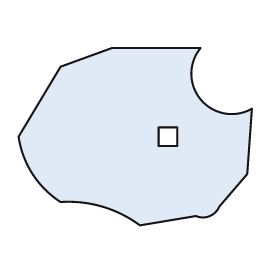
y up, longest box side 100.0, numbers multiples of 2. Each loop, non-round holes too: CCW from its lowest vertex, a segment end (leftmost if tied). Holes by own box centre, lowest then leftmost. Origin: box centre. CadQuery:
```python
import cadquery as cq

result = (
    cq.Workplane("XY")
    .moveTo(2.0, -38.0)
    .lineTo(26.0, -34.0)
    .threePointArc((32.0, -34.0), (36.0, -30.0))
    .lineTo(48.0, -16.0)
    .lineTo(50.0, 12.0)
    .threePointArc((28.0, 16.0), (28.0, 38.0))
    .lineTo(-10.0, 38.0)
    .lineTo(-32.0, 30.0)
    .lineTo(-50.0, 0.0)
    .threePointArc((-44.0, -16.0), (-32.0, -28.0))
    .threePointArc((-14.0, -30.0), (2.0, -38.0))
    .close()
    .moveTo(10.0, -4.0)
    .lineTo(18.0, -4.0)
    .lineTo(18.0, 4.0)
    .lineTo(10.0, 4.0)
    .close()
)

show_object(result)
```